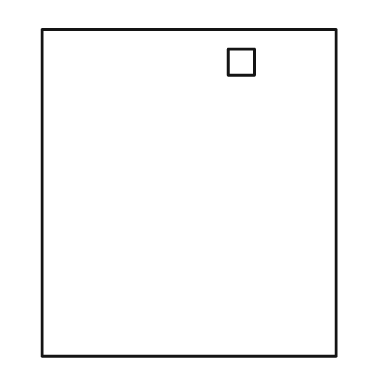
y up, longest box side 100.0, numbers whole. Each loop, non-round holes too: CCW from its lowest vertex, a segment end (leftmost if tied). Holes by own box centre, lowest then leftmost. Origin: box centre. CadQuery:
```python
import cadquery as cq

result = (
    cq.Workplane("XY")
    .moveTo(-45.0, -50.0)
    .lineTo(45.0, -50.0)
    .lineTo(45.0, 50.0)
    .lineTo(-45.0, 50.0)
    .close()
    .moveTo(12.0, 36.0)
    .lineTo(20.0, 36.0)
    .lineTo(20.0, 44.0)
    .lineTo(12.0, 44.0)
    .close()
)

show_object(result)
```